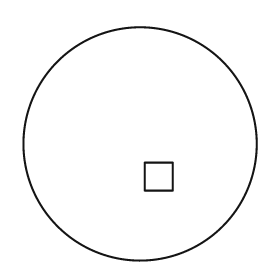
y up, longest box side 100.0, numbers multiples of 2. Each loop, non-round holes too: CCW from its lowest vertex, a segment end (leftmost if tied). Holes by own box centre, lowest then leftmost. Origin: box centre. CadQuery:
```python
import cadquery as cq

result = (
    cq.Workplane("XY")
    .moveTo(0.0, 0.0)
    .circle(50.0)
    .moveTo(2.0, -20.0)
    .lineTo(14.0, -20.0)
    .lineTo(14.0, -8.0)
    .lineTo(2.0, -8.0)
    .close()
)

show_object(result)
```